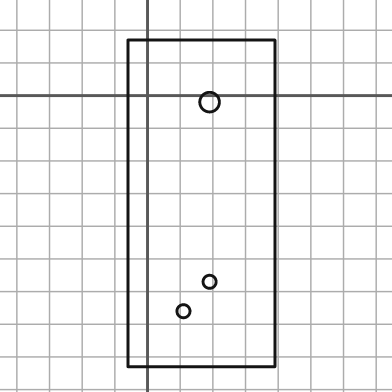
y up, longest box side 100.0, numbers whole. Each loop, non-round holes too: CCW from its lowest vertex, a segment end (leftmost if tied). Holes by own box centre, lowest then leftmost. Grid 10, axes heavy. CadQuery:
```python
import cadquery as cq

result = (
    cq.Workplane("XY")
    .moveTo(-6.0, -83.0)
    .lineTo(39.0, -83.0)
    .lineTo(39.0, 17.0)
    .lineTo(-6.0, 17.0)
    .close()
    .moveTo(11.0, -66.0)
    .circle(2.0)
    .moveTo(19.0, -57.0)
    .circle(2.0)
    .moveTo(19.0, -2.0)
    .circle(3.0)
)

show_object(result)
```